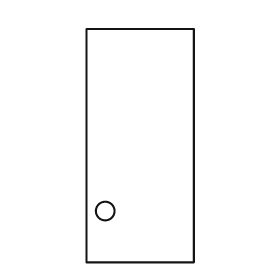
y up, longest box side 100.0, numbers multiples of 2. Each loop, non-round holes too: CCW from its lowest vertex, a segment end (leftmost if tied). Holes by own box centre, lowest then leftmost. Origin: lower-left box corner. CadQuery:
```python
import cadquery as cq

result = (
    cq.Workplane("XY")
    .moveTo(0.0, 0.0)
    .lineTo(46.0, 0.0)
    .lineTo(46.0, 100.0)
    .lineTo(0.0, 100.0)
    .close()
    .moveTo(8.0, 22.0)
    .circle(4.0)
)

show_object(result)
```